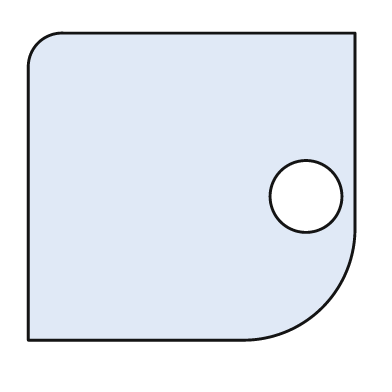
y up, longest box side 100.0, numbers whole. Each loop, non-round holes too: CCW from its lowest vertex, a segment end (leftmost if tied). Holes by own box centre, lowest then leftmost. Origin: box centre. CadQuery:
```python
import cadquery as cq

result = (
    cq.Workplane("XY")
    .moveTo(-50.0, -47.0)
    .lineTo(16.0, -47.0)
    .threePointArc((40.0, -37.0), (50.0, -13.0))
    .lineTo(50.0, 47.0)
    .lineTo(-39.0, 47.0)
    .threePointArc((-47.0, 44.0), (-50.0, 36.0))
    .close()
    .moveTo(35.0, -3.0)
    .circle(11.0)
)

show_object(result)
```